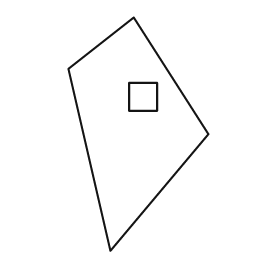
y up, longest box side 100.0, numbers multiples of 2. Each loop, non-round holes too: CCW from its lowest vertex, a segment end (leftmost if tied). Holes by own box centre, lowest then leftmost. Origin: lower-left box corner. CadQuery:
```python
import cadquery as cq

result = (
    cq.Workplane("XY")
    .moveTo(18.0, 0.0)
    .lineTo(60.0, 50.0)
    .lineTo(28.0, 100.0)
    .lineTo(0.0, 78.0)
    .close()
    .moveTo(26.0, 60.0)
    .lineTo(38.0, 60.0)
    .lineTo(38.0, 72.0)
    .lineTo(26.0, 72.0)
    .close()
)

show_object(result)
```